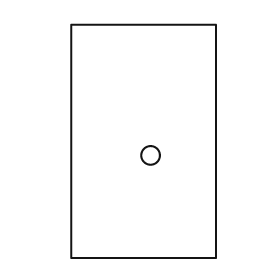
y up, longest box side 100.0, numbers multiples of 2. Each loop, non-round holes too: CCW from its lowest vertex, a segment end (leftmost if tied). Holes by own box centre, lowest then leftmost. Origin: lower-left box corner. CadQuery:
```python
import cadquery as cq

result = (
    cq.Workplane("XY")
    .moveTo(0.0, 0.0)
    .lineTo(62.0, 0.0)
    .lineTo(62.0, 100.0)
    .lineTo(0.0, 100.0)
    .close()
    .moveTo(34.0, 44.0)
    .circle(4.0)
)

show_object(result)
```